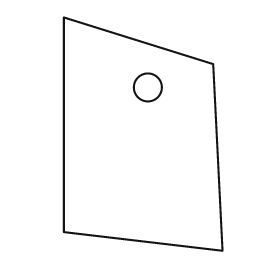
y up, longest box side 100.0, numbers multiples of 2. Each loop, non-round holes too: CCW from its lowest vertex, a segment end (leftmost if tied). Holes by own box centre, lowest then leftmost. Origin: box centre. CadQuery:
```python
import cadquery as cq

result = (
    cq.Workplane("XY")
    .moveTo(34.0, -50.0)
    .lineTo(30.0, 30.0)
    .lineTo(-34.0, 50.0)
    .lineTo(-34.0, -42.0)
    .close()
    .moveTo(2.0, 20.0)
    .circle(6.0)
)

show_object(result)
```